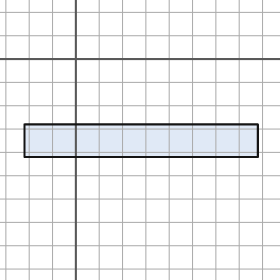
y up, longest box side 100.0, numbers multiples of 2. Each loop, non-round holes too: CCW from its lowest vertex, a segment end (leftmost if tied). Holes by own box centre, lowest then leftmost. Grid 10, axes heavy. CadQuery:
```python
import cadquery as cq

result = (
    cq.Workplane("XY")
    .moveTo(-22.0, -42.0)
    .lineTo(78.0, -42.0)
    .lineTo(78.0, -28.0)
    .lineTo(-22.0, -28.0)
    .close()
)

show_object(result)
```